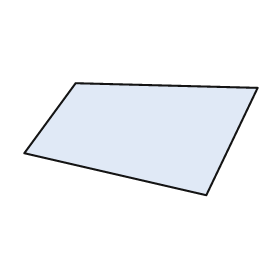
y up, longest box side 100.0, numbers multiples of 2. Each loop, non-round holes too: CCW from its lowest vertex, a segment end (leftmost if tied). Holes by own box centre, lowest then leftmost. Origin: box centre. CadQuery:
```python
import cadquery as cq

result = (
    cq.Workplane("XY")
    .moveTo(28.0, -24.0)
    .lineTo(50.0, 22.0)
    .lineTo(-28.0, 24.0)
    .lineTo(-50.0, -6.0)
    .close()
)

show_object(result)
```